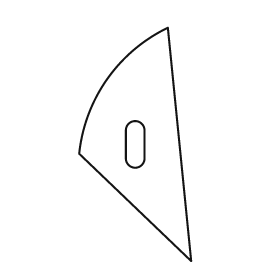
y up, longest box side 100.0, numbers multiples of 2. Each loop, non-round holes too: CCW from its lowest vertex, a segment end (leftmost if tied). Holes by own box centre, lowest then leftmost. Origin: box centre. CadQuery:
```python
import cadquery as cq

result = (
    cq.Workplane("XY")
    .moveTo(24.0, -50.0)
    .lineTo(14.0, 50.0)
    .threePointArc((-12.0, 28.0), (-24.0, -4.0))
    .close()
    .moveTo(-4.0, -6.0)
    .threePointArc((0.0, -10.0), (4.0, -6.0))
    .lineTo(4.0, 6.0)
    .threePointArc((0.0, 10.0), (-4.0, 6.0))
    .close()
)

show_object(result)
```